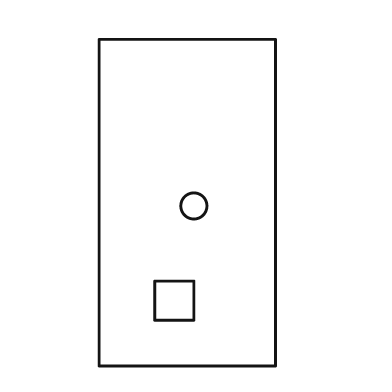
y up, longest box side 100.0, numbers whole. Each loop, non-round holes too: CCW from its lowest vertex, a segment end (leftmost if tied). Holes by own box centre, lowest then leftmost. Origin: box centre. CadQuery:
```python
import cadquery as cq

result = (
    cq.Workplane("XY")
    .moveTo(-27.0, -50.0)
    .lineTo(27.0, -50.0)
    .lineTo(27.0, 50.0)
    .lineTo(-27.0, 50.0)
    .close()
    .moveTo(-10.0, -36.0)
    .lineTo(2.0, -36.0)
    .lineTo(2.0, -24.0)
    .lineTo(-10.0, -24.0)
    .close()
    .moveTo(2.0, -1.0)
    .circle(4.0)
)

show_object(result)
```